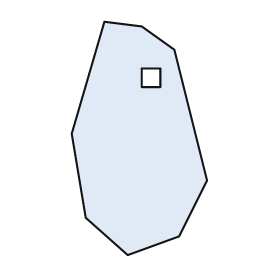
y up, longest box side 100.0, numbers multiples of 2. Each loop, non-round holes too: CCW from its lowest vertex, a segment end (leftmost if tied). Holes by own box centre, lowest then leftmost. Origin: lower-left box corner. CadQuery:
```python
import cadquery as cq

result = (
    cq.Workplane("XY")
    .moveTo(24.0, 0.0)
    .lineTo(46.0, 8.0)
    .lineTo(58.0, 32.0)
    .lineTo(44.0, 88.0)
    .lineTo(30.0, 98.0)
    .lineTo(14.0, 100.0)
    .lineTo(0.0, 52.0)
    .lineTo(6.0, 16.0)
    .close()
    .moveTo(30.0, 72.0)
    .lineTo(38.0, 72.0)
    .lineTo(38.0, 80.0)
    .lineTo(30.0, 80.0)
    .close()
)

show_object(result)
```